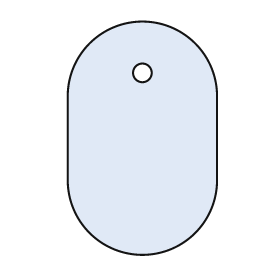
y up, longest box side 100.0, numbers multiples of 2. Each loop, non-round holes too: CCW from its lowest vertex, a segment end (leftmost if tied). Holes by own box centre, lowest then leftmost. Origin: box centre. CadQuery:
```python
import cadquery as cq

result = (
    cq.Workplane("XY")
    .moveTo(-32.0, -18.0)
    .threePointArc((0.0, -50.0), (32.0, -18.0))
    .lineTo(32.0, 18.0)
    .threePointArc((0.0, 50.0), (-32.0, 18.0))
    .close()
    .moveTo(0.0, 28.0)
    .circle(4.0)
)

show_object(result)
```